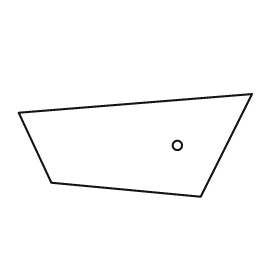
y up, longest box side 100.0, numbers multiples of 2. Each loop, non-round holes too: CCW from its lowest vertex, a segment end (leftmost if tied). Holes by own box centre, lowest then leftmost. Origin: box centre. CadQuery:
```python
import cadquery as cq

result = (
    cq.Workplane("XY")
    .moveTo(28.0, -22.0)
    .lineTo(50.0, 22.0)
    .lineTo(-50.0, 14.0)
    .lineTo(-36.0, -16.0)
    .close()
    .moveTo(18.0, 0.0)
    .circle(2.0)
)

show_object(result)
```